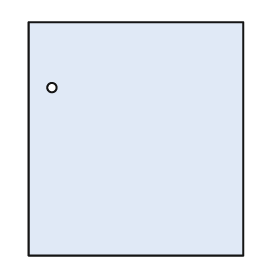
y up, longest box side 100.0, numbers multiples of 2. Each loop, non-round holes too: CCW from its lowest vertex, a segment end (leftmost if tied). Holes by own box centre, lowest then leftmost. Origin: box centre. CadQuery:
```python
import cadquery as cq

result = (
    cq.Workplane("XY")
    .moveTo(-46.0, -50.0)
    .lineTo(46.0, -50.0)
    .lineTo(46.0, 50.0)
    .lineTo(-46.0, 50.0)
    .close()
    .moveTo(-36.0, 22.0)
    .circle(2.0)
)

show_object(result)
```